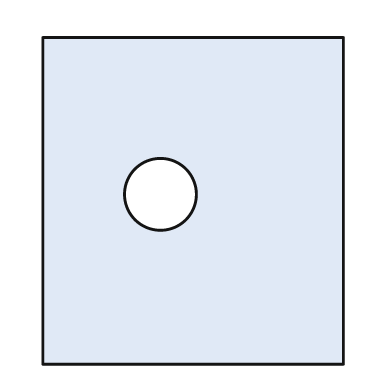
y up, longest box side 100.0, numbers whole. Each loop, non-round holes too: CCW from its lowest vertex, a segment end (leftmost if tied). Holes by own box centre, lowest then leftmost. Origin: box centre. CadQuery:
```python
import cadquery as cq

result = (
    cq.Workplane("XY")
    .moveTo(-46.0, -50.0)
    .lineTo(46.0, -50.0)
    .lineTo(46.0, 50.0)
    .lineTo(-46.0, 50.0)
    .close()
    .moveTo(-10.0, 2.0)
    .circle(11.0)
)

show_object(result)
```